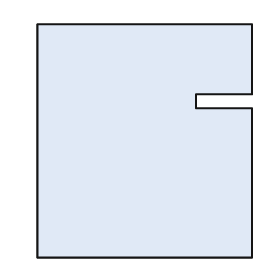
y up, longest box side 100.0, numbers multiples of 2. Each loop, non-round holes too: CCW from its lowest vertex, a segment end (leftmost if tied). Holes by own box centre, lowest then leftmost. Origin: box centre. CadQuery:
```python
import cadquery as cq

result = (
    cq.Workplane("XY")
    .moveTo(-46.0, -50.0)
    .lineTo(46.0, -50.0)
    .lineTo(46.0, 14.0)
    .lineTo(22.0, 14.0)
    .lineTo(22.0, 20.0)
    .lineTo(46.0, 20.0)
    .lineTo(46.0, 50.0)
    .lineTo(-46.0, 50.0)
    .close()
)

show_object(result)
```